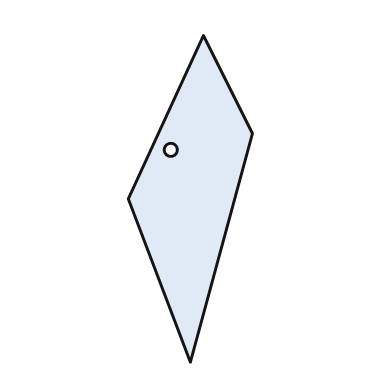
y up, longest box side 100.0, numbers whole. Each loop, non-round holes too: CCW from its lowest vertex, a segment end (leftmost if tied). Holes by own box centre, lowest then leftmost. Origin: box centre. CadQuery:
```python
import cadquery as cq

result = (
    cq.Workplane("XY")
    .moveTo(0.0, -50.0)
    .lineTo(19.0, 20.0)
    .lineTo(4.0, 50.0)
    .lineTo(-19.0, 0.0)
    .close()
    .moveTo(-6.0, 15.0)
    .circle(2.0)
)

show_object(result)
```